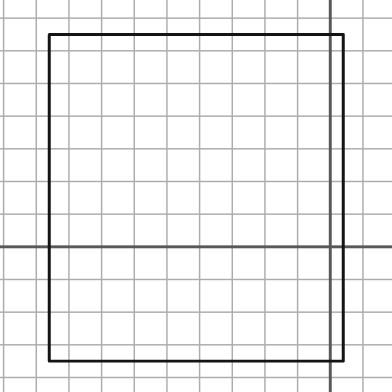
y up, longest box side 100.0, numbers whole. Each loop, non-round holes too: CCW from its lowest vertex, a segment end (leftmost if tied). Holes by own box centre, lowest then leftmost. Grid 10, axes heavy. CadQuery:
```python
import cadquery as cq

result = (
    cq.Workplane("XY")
    .moveTo(-86.0, -35.0)
    .lineTo(4.0, -35.0)
    .lineTo(4.0, 65.0)
    .lineTo(-86.0, 65.0)
    .close()
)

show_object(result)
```